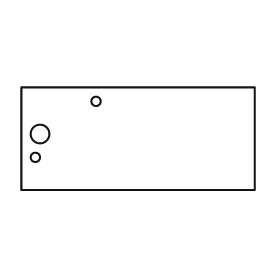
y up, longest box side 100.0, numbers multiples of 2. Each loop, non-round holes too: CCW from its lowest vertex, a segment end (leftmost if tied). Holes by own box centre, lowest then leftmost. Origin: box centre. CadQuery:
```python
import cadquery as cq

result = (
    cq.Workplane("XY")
    .moveTo(-50.0, -22.0)
    .lineTo(50.0, -22.0)
    .lineTo(50.0, 22.0)
    .lineTo(-50.0, 22.0)
    .close()
    .moveTo(-44.0, -8.0)
    .circle(2.0)
    .moveTo(-42.0, 2.0)
    .circle(4.0)
    .moveTo(-18.0, 16.0)
    .circle(2.0)
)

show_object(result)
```